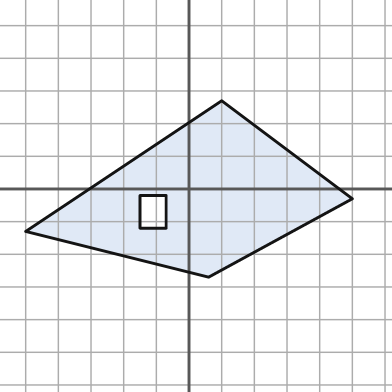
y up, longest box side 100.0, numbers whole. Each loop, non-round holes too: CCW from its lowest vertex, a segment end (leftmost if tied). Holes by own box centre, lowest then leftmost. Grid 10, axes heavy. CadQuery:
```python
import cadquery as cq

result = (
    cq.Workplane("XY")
    .moveTo(6.0, -27.0)
    .lineTo(50.0, -3.0)
    .lineTo(10.0, 27.0)
    .lineTo(-50.0, -13.0)
    .close()
    .moveTo(-15.0, -12.0)
    .lineTo(-7.0, -12.0)
    .lineTo(-7.0, -2.0)
    .lineTo(-15.0, -2.0)
    .close()
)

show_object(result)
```